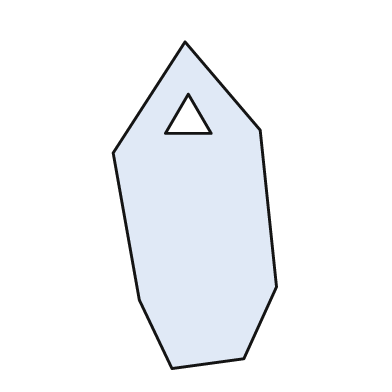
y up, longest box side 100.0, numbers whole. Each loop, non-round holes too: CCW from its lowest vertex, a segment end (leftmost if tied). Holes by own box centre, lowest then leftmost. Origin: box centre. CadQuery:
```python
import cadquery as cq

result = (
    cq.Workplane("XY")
    .moveTo(-7.0, -50.0)
    .lineTo(15.0, -47.0)
    .lineTo(25.0, -25.0)
    .lineTo(20.0, 23.0)
    .lineTo(-3.0, 50.0)
    .lineTo(-25.0, 16.0)
    .lineTo(-17.0, -29.0)
    .close()
    .moveTo(-9.0, 22.0)
    .lineTo(5.0, 22.0)
    .lineTo(-2.0, 34.0)
    .close()
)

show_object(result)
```